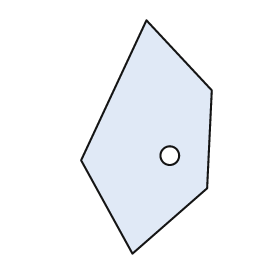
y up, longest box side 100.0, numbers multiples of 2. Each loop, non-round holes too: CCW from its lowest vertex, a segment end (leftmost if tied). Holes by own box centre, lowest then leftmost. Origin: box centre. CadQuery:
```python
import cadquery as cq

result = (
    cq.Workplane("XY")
    .moveTo(-6.0, -50.0)
    .lineTo(26.0, -22.0)
    .lineTo(28.0, 20.0)
    .lineTo(0.0, 50.0)
    .lineTo(-28.0, -10.0)
    .close()
    .moveTo(10.0, -8.0)
    .circle(4.0)
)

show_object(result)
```